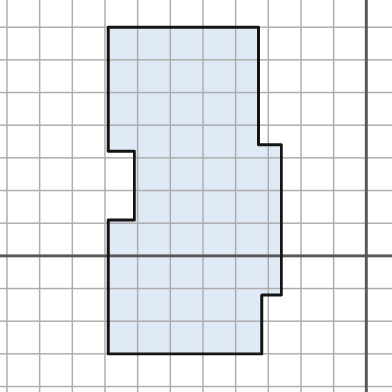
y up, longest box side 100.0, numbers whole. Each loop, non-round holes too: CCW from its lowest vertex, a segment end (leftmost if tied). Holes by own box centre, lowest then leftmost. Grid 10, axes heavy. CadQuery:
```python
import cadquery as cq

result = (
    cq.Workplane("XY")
    .moveTo(-79.0, -30.0)
    .lineTo(-32.0, -30.0)
    .lineTo(-32.0, -12.0)
    .lineTo(-26.0, -12.0)
    .lineTo(-26.0, 34.0)
    .lineTo(-33.0, 34.0)
    .lineTo(-33.0, 70.0)
    .lineTo(-79.0, 70.0)
    .lineTo(-79.0, 32.0)
    .lineTo(-71.0, 32.0)
    .lineTo(-71.0, 11.0)
    .lineTo(-79.0, 11.0)
    .close()
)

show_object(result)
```